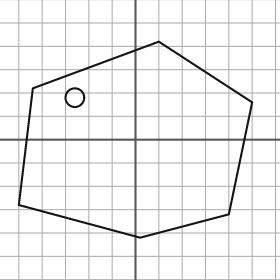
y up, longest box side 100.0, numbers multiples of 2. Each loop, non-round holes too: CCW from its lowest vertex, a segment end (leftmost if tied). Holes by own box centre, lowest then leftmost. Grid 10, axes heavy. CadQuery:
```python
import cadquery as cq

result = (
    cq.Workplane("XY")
    .moveTo(2.0, -42.0)
    .lineTo(40.0, -32.0)
    .lineTo(50.0, 16.0)
    .lineTo(10.0, 42.0)
    .lineTo(-44.0, 22.0)
    .lineTo(-50.0, -28.0)
    .close()
    .moveTo(-26.0, 18.0)
    .circle(4.0)
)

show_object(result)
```